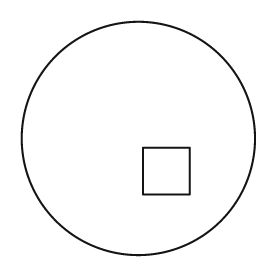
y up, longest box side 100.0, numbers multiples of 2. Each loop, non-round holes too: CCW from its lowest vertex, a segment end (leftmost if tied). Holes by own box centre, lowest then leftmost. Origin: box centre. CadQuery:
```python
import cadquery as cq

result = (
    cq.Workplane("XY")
    .moveTo(0.0, 0.0)
    .circle(50.0)
    .moveTo(2.0, -24.0)
    .lineTo(22.0, -24.0)
    .lineTo(22.0, -4.0)
    .lineTo(2.0, -4.0)
    .close()
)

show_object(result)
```